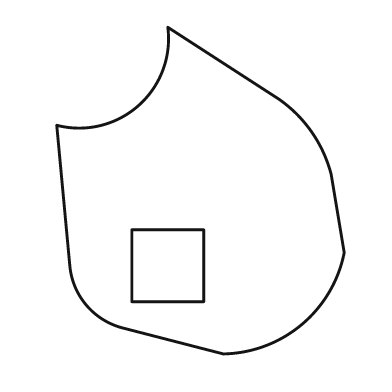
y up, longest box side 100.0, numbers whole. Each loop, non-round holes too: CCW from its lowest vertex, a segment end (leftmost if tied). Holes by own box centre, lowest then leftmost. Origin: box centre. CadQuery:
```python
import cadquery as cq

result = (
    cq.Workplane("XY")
    .moveTo(7.0, -50.0)
    .threePointArc((31.0, -41.0), (44.0, -19.0))
    .lineTo(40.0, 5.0)
    .threePointArc((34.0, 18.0), (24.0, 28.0))
    .lineTo(-10.0, 50.0)
    .threePointArc((-19.0, 26.0), (-44.0, 20.0))
    .lineTo(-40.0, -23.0)
    .threePointArc((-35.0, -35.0), (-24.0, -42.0))
    .close()
    .moveTo(-21.0, -34.0)
    .lineTo(1.0, -34.0)
    .lineTo(1.0, -12.0)
    .lineTo(-21.0, -12.0)
    .close()
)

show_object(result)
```